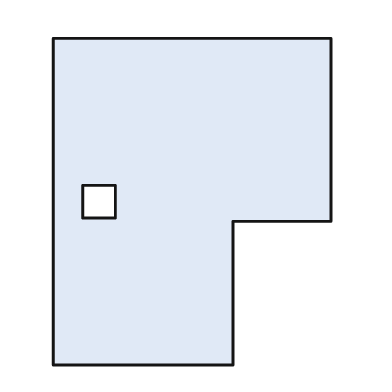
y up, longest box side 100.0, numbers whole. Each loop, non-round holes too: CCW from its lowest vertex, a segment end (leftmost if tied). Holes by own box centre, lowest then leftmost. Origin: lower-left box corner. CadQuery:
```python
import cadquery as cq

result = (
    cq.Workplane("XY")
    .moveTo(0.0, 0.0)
    .lineTo(55.0, 0.0)
    .lineTo(55.0, 44.0)
    .lineTo(85.0, 44.0)
    .lineTo(85.0, 100.0)
    .lineTo(0.0, 100.0)
    .close()
    .moveTo(9.0, 45.0)
    .lineTo(19.0, 45.0)
    .lineTo(19.0, 55.0)
    .lineTo(9.0, 55.0)
    .close()
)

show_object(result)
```